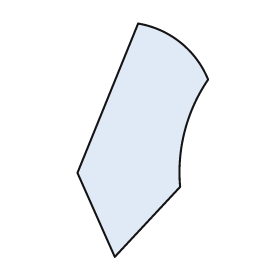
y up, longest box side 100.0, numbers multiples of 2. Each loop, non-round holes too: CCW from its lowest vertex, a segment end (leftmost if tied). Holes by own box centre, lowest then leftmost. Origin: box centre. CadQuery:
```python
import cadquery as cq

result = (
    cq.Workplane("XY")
    .moveTo(-12.0, -50.0)
    .lineTo(16.0, -20.0)
    .threePointArc((18.0, 4.0), (28.0, 26.0))
    .threePointArc((16.0, 42.0), (-2.0, 50.0))
    .lineTo(-28.0, -14.0)
    .close()
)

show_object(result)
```